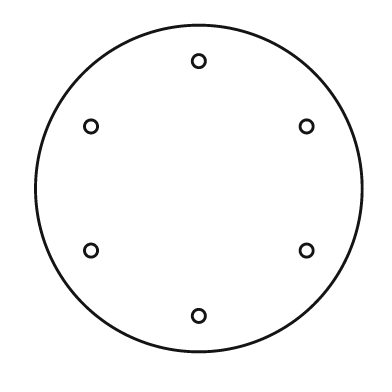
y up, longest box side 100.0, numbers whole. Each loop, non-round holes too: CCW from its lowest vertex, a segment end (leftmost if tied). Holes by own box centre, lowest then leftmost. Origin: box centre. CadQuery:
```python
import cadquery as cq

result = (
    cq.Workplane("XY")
    .moveTo(0.0, 0.0)
    .circle(50.0)
    .moveTo(0.0, -39.0)
    .circle(2.0)
    .moveTo(-33.0, -19.0)
    .circle(2.0)
    .moveTo(33.0, -19.0)
    .circle(2.0)
    .moveTo(-33.0, 19.0)
    .circle(2.0)
    .moveTo(33.0, 19.0)
    .circle(2.0)
    .moveTo(0.0, 39.0)
    .circle(2.0)
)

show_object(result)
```